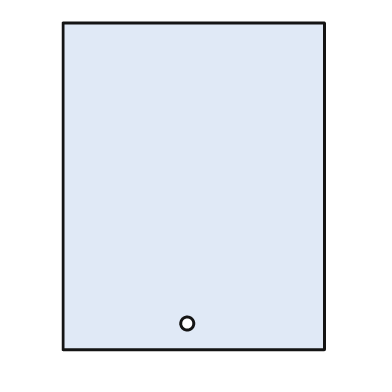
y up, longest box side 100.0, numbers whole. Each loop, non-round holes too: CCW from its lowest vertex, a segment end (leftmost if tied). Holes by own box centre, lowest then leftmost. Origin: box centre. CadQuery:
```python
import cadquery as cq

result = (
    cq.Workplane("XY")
    .moveTo(-40.0, -50.0)
    .lineTo(40.0, -50.0)
    .lineTo(40.0, 50.0)
    .lineTo(-40.0, 50.0)
    .close()
    .moveTo(-2.0, -42.0)
    .circle(2.0)
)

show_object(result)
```